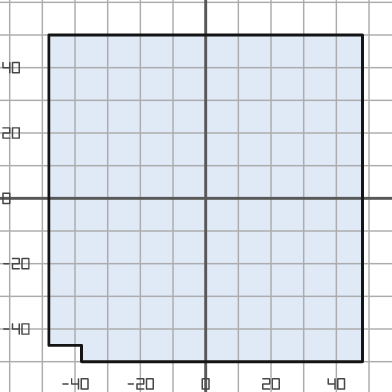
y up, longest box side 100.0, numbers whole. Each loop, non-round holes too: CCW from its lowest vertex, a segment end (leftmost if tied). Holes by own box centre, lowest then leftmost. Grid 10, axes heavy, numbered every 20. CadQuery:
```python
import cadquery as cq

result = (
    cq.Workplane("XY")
    .moveTo(-38.0, -50.0)
    .lineTo(48.0, -50.0)
    .lineTo(48.0, 50.0)
    .lineTo(-48.0, 50.0)
    .lineTo(-48.0, -45.0)
    .lineTo(-38.0, -45.0)
    .close()
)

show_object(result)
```